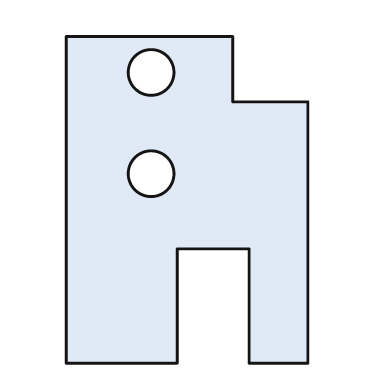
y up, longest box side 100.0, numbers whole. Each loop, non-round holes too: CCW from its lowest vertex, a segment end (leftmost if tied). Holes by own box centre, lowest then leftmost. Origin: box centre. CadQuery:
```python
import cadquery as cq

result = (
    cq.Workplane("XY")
    .moveTo(-37.0, -50.0)
    .lineTo(-3.0, -50.0)
    .lineTo(-3.0, -15.0)
    .lineTo(19.0, -15.0)
    .lineTo(19.0, -50.0)
    .lineTo(37.0, -50.0)
    .lineTo(37.0, 30.0)
    .lineTo(14.0, 30.0)
    .lineTo(14.0, 50.0)
    .lineTo(-37.0, 50.0)
    .close()
    .moveTo(-11.0, 8.0)
    .circle(7.0)
    .moveTo(-11.0, 39.0)
    .circle(7.0)
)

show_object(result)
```